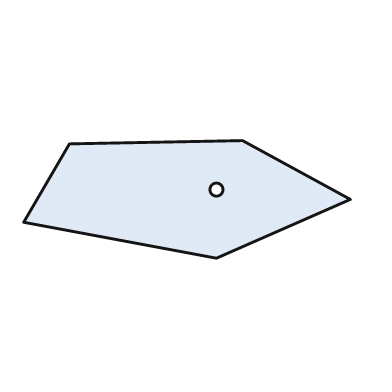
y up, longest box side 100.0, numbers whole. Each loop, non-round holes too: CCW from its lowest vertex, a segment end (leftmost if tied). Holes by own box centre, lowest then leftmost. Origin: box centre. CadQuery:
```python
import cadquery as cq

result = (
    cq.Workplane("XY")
    .moveTo(9.0, -18.0)
    .lineTo(50.0, 0.0)
    .lineTo(17.0, 18.0)
    .lineTo(-36.0, 17.0)
    .lineTo(-50.0, -7.0)
    .close()
    .moveTo(9.0, 3.0)
    .circle(2.0)
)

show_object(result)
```